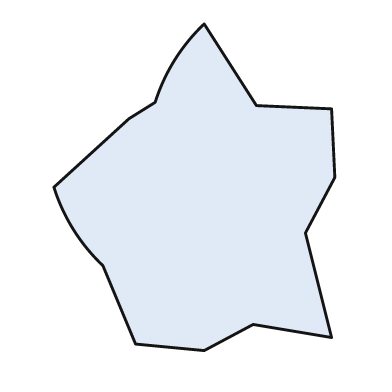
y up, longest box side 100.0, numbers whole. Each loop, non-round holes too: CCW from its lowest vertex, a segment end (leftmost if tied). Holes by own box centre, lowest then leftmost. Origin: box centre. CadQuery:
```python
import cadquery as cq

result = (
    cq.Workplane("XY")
    .moveTo(3.0, -50.0)
    .lineTo(18.0, -42.0)
    .lineTo(42.0, -46.0)
    .lineTo(34.0, -14.0)
    .lineTo(43.0, 3.0)
    .lineTo(42.0, 24.0)
    .lineTo(19.0, 25.0)
    .lineTo(3.0, 50.0)
    .threePointArc((-6.0, 39.0), (-12.0, 26.0))
    .lineTo(-20.0, 21.0)
    .lineTo(-43.0, 0.0)
    .threePointArc((-37.0, -13.0), (-28.0, -24.0))
    .lineTo(-18.0, -48.0)
    .close()
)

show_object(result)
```